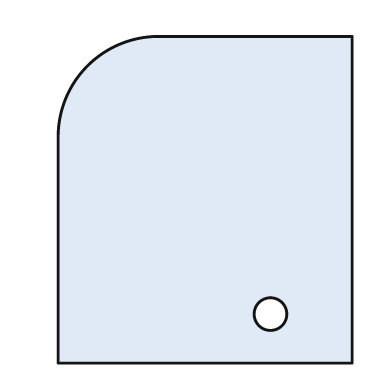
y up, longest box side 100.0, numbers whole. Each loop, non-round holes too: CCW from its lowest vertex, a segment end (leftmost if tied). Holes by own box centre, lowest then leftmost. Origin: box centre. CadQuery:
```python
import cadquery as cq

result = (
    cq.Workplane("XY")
    .moveTo(-45.0, -50.0)
    .lineTo(45.0, -50.0)
    .lineTo(45.0, 50.0)
    .lineTo(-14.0, 50.0)
    .threePointArc((-36.0, 41.0), (-45.0, 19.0))
    .close()
    .moveTo(20.0, -35.0)
    .circle(5.0)
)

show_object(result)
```